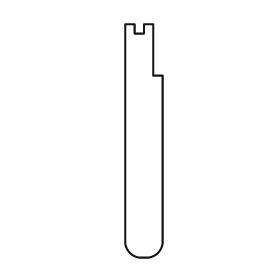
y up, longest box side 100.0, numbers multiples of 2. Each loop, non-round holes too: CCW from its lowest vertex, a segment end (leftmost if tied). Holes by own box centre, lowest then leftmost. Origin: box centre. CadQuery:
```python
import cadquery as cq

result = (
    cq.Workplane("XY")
    .moveTo(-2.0, -50.0)
    .lineTo(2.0, -50.0)
    .threePointArc((6.0, -48.0), (8.0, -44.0))
    .lineTo(8.0, 28.0)
    .lineTo(4.0, 28.0)
    .lineTo(4.0, 50.0)
    .lineTo(0.0, 50.0)
    .lineTo(0.0, 46.0)
    .lineTo(-4.0, 46.0)
    .lineTo(-4.0, 50.0)
    .lineTo(-8.0, 50.0)
    .lineTo(-8.0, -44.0)
    .threePointArc((-6.0, -48.0), (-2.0, -50.0))
    .close()
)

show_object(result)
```